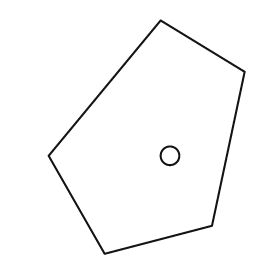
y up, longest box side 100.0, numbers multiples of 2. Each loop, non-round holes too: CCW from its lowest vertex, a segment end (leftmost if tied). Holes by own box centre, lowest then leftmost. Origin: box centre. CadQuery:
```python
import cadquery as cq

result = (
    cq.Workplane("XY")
    .moveTo(-18.0, -50.0)
    .lineTo(28.0, -38.0)
    .lineTo(42.0, 28.0)
    .lineTo(6.0, 50.0)
    .lineTo(-42.0, -8.0)
    .close()
    .moveTo(10.0, -8.0)
    .circle(4.0)
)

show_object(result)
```